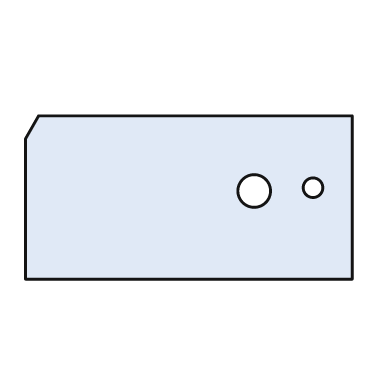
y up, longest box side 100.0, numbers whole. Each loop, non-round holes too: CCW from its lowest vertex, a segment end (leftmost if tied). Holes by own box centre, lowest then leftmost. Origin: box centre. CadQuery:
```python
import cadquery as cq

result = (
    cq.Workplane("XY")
    .moveTo(-50.0, -25.0)
    .lineTo(50.0, -25.0)
    .lineTo(50.0, 25.0)
    .lineTo(-46.0, 25.0)
    .lineTo(-50.0, 18.0)
    .close()
    .moveTo(20.0, 2.0)
    .circle(5.0)
    .moveTo(38.0, 3.0)
    .circle(3.0)
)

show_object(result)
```